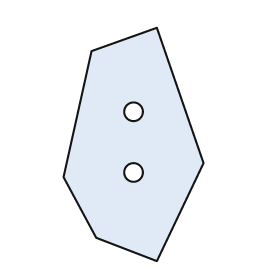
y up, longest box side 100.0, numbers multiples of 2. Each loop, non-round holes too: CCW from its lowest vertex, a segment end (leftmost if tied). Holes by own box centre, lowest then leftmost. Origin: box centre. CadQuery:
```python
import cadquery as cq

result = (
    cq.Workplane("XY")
    .moveTo(10.0, -50.0)
    .lineTo(30.0, -8.0)
    .lineTo(10.0, 50.0)
    .lineTo(-18.0, 40.0)
    .lineTo(-30.0, -14.0)
    .lineTo(-16.0, -40.0)
    .close()
    .moveTo(0.0, -12.0)
    .circle(4.0)
    .moveTo(0.0, 14.0)
    .circle(4.0)
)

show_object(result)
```